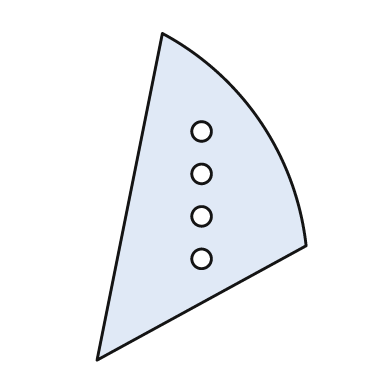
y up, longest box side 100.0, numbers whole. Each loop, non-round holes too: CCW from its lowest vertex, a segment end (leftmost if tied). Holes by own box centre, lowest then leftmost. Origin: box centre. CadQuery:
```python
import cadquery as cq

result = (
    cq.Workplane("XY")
    .moveTo(-32.0, -50.0)
    .lineTo(32.0, -15.0)
    .threePointArc((18.0, 23.0), (-12.0, 50.0))
    .close()
    .moveTo(0.0, -19.0)
    .circle(3.0)
    .moveTo(0.0, -6.0)
    .circle(3.0)
    .moveTo(0.0, 7.0)
    .circle(3.0)
    .moveTo(0.0, 20.0)
    .circle(3.0)
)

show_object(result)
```